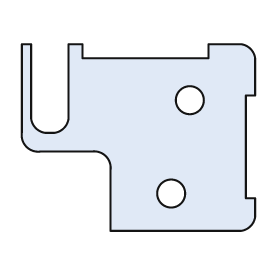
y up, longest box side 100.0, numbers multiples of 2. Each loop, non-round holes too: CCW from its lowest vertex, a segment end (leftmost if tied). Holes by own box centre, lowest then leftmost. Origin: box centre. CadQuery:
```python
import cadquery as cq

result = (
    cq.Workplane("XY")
    .moveTo(-12.0, -40.0)
    .lineTo(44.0, -40.0)
    .threePointArc((48.0, -38.0), (50.0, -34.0))
    .lineTo(50.0, -26.0)
    .lineTo(46.0, -26.0)
    .lineTo(46.0, 18.0)
    .lineTo(50.0, 18.0)
    .lineTo(50.0, 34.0)
    .threePointArc((48.0, 38.0), (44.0, 40.0))
    .lineTo(30.0, 40.0)
    .lineTo(30.0, 34.0)
    .lineTo(-24.0, 34.0)
    .lineTo(-24.0, 40.0)
    .lineTo(-30.0, 40.0)
    .lineTo(-30.0, 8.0)
    .threePointArc((-32.0, 4.0), (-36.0, 2.0))
    .lineTo(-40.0, 2.0)
    .threePointArc((-44.0, 4.0), (-46.0, 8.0))
    .lineTo(-46.0, 40.0)
    .lineTo(-50.0, 40.0)
    .lineTo(-50.0, 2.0)
    .threePointArc((-48.0, -4.0), (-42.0, -6.0))
    .lineTo(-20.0, -6.0)
    .threePointArc((-14.0, -8.0), (-12.0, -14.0))
    .close()
    .moveTo(14.0, -24.0)
    .circle(6.0)
    .moveTo(22.0, 16.0)
    .circle(6.0)
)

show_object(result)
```